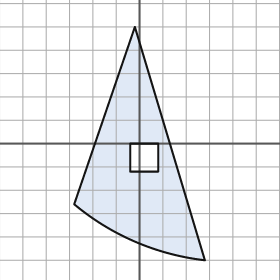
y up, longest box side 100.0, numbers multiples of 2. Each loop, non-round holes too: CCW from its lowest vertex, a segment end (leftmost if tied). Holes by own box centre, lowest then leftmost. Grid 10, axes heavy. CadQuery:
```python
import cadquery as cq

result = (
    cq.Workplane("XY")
    .moveTo(28.0, -50.0)
    .lineTo(-2.0, 50.0)
    .lineTo(-28.0, -26.0)
    .threePointArc((-2.0, -42.0), (28.0, -50.0))
    .close()
    .moveTo(-4.0, -12.0)
    .lineTo(8.0, -12.0)
    .lineTo(8.0, 0.0)
    .lineTo(-4.0, 0.0)
    .close()
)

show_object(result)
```